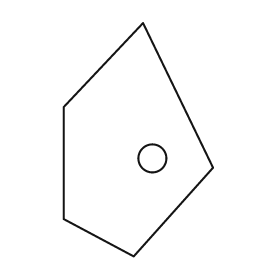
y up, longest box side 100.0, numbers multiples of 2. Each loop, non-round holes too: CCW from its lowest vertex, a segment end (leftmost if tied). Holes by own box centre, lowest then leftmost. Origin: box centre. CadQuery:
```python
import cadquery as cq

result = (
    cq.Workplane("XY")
    .moveTo(-2.0, -50.0)
    .lineTo(32.0, -12.0)
    .lineTo(2.0, 50.0)
    .lineTo(-32.0, 14.0)
    .lineTo(-32.0, -34.0)
    .close()
    .moveTo(6.0, -8.0)
    .circle(6.0)
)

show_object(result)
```